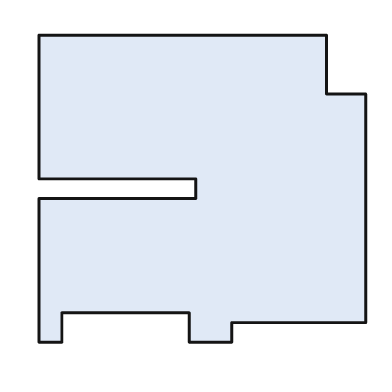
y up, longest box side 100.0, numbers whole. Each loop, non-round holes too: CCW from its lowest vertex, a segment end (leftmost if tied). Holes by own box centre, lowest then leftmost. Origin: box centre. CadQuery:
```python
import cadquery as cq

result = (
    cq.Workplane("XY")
    .moveTo(-50.0, -47.0)
    .lineTo(-43.0, -47.0)
    .lineTo(-43.0, -38.0)
    .lineTo(-4.0, -38.0)
    .lineTo(-4.0, -47.0)
    .lineTo(9.0, -47.0)
    .lineTo(9.0, -41.0)
    .lineTo(50.0, -41.0)
    .lineTo(50.0, 29.0)
    .lineTo(38.0, 29.0)
    .lineTo(38.0, 47.0)
    .lineTo(-50.0, 47.0)
    .lineTo(-50.0, 3.0)
    .lineTo(-2.0, 3.0)
    .lineTo(-2.0, -3.0)
    .lineTo(-50.0, -3.0)
    .close()
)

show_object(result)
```